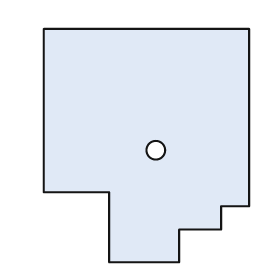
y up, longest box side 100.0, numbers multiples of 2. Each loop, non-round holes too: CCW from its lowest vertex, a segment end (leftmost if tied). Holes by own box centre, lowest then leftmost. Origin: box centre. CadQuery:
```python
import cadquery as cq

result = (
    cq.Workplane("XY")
    .moveTo(-16.0, -50.0)
    .lineTo(14.0, -50.0)
    .lineTo(14.0, -36.0)
    .lineTo(32.0, -36.0)
    .lineTo(32.0, -26.0)
    .lineTo(44.0, -26.0)
    .lineTo(44.0, 50.0)
    .lineTo(-44.0, 50.0)
    .lineTo(-44.0, -20.0)
    .lineTo(-16.0, -20.0)
    .close()
    .moveTo(4.0, -2.0)
    .circle(4.0)
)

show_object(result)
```